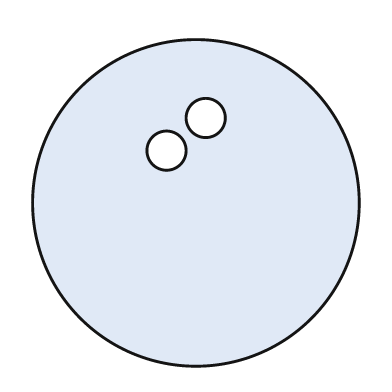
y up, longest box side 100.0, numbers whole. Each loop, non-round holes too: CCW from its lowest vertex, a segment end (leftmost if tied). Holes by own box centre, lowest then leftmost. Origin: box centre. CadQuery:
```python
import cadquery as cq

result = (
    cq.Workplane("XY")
    .moveTo(0.0, 0.0)
    .circle(50.0)
    .moveTo(-9.0, 16.0)
    .circle(6.0)
    .moveTo(3.0, 26.0)
    .circle(6.0)
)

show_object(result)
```